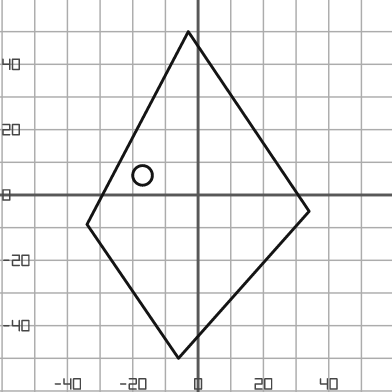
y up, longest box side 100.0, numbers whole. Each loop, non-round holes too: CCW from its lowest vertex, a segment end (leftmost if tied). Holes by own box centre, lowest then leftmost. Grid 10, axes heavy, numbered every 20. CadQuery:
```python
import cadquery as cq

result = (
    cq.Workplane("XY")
    .moveTo(-6.0, -50.0)
    .lineTo(34.0, -5.0)
    .lineTo(-3.0, 50.0)
    .lineTo(-34.0, -9.0)
    .close()
    .moveTo(-17.0, 6.0)
    .circle(3.0)
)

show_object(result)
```